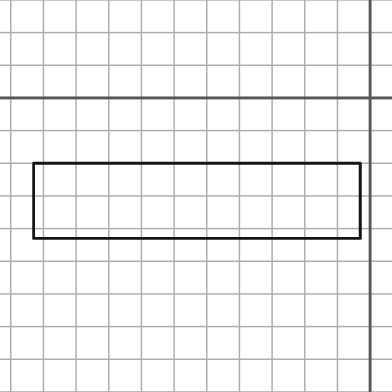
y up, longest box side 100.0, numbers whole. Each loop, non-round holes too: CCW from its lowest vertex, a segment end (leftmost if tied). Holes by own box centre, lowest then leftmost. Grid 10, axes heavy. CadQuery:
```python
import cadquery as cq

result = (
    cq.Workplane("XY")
    .moveTo(-103.0, -43.0)
    .lineTo(-3.0, -43.0)
    .lineTo(-3.0, -20.0)
    .lineTo(-103.0, -20.0)
    .close()
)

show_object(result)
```